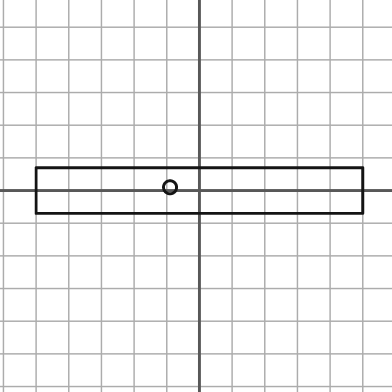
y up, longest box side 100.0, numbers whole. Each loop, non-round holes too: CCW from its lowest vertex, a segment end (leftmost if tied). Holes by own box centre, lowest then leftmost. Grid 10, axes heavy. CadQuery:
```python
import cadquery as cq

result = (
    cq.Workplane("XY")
    .moveTo(-50.0, -7.0)
    .lineTo(50.0, -7.0)
    .lineTo(50.0, 7.0)
    .lineTo(-50.0, 7.0)
    .close()
    .moveTo(-9.0, 1.0)
    .circle(2.0)
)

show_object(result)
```